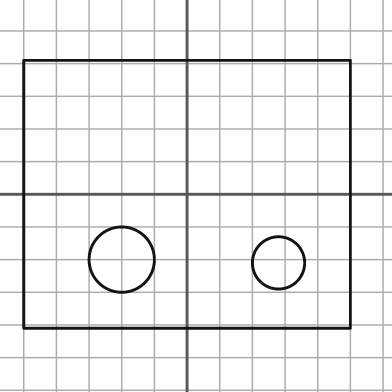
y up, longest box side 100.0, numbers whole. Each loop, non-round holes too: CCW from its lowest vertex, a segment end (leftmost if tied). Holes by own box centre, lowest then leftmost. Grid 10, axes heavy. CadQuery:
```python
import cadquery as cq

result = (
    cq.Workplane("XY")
    .moveTo(-50.0, -41.0)
    .lineTo(50.0, -41.0)
    .lineTo(50.0, 41.0)
    .lineTo(-50.0, 41.0)
    .close()
    .moveTo(28.0, -21.0)
    .circle(8.0)
    .moveTo(-20.0, -20.0)
    .circle(10.0)
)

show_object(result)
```